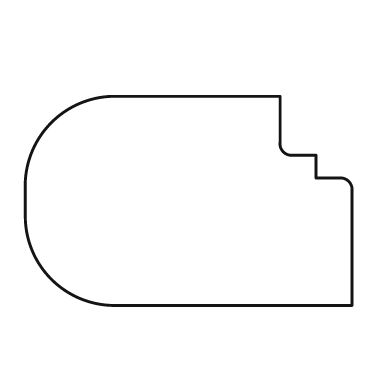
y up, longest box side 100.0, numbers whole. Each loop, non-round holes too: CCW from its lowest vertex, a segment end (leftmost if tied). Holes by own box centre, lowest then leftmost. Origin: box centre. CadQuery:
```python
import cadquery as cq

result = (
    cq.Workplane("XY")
    .moveTo(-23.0, -32.0)
    .lineTo(50.0, -32.0)
    .lineTo(50.0, 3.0)
    .threePointArc((49.0, 6.0), (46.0, 7.0))
    .lineTo(39.0, 7.0)
    .lineTo(39.0, 14.0)
    .lineTo(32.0, 14.0)
    .threePointArc((29.0, 15.0), (28.0, 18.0))
    .lineTo(28.0, 32.0)
    .lineTo(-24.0, 32.0)
    .threePointArc((-42.0, 24.0), (-50.0, 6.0))
    .lineTo(-50.0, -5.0)
    .threePointArc((-42.0, -24.0), (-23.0, -32.0))
    .close()
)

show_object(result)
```